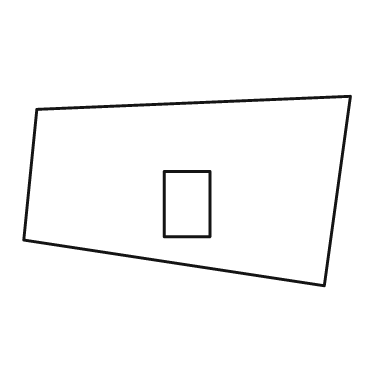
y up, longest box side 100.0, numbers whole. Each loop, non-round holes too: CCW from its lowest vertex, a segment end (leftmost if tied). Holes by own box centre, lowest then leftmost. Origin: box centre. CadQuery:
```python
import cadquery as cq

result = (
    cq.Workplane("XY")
    .moveTo(42.0, -29.0)
    .lineTo(50.0, 29.0)
    .lineTo(-46.0, 25.0)
    .lineTo(-50.0, -15.0)
    .close()
    .moveTo(-7.0, -14.0)
    .lineTo(7.0, -14.0)
    .lineTo(7.0, 6.0)
    .lineTo(-7.0, 6.0)
    .close()
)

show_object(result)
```